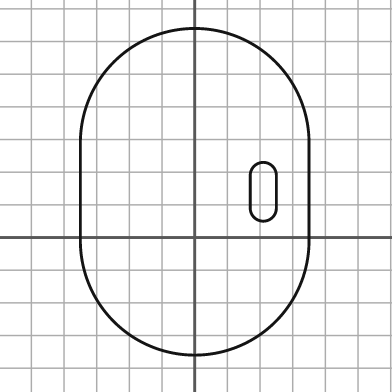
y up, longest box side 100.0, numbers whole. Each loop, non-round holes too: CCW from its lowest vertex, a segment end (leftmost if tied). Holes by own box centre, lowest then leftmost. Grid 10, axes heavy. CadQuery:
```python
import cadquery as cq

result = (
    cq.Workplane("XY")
    .moveTo(-35.0, -1.0)
    .threePointArc((0.0, -36.0), (35.0, -1.0))
    .lineTo(35.0, 29.0)
    .threePointArc((0.0, 64.0), (-35.0, 29.0))
    .close()
    .moveTo(17.0, 9.0)
    .threePointArc((21.0, 5.0), (25.0, 9.0))
    .lineTo(25.0, 19.0)
    .threePointArc((21.0, 23.0), (17.0, 19.0))
    .close()
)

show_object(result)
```